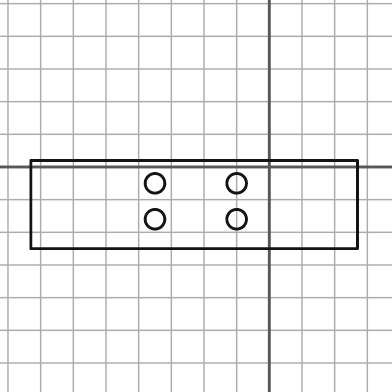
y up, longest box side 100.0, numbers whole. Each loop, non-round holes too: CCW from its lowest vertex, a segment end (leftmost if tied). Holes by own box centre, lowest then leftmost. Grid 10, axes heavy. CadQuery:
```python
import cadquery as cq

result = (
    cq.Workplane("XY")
    .moveTo(-73.0, -25.0)
    .lineTo(27.0, -25.0)
    .lineTo(27.0, 2.0)
    .lineTo(-73.0, 2.0)
    .close()
    .moveTo(-35.0, -16.0)
    .circle(3.0)
    .moveTo(-10.0, -16.0)
    .circle(3.0)
    .moveTo(-35.0, -5.0)
    .circle(3.0)
    .moveTo(-10.0, -5.0)
    .circle(3.0)
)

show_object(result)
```